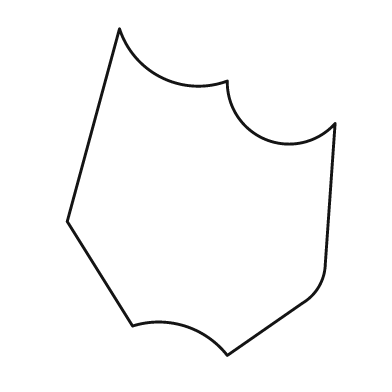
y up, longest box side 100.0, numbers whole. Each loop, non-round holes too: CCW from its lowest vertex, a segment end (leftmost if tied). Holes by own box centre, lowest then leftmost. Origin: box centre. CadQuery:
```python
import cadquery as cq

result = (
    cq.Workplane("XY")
    .moveTo(8.0, -50.0)
    .lineTo(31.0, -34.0)
    .threePointArc((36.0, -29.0), (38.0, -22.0))
    .lineTo(41.0, 21.0)
    .threePointArc((20.0, 16.0), (8.0, 34.0))
    .threePointArc((-12.0, 35.0), (-25.0, 50.0))
    .lineTo(-41.0, -9.0)
    .lineTo(-21.0, -41.0)
    .threePointArc((-5.0, -41.0), (8.0, -50.0))
    .close()
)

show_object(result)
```